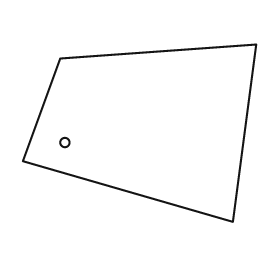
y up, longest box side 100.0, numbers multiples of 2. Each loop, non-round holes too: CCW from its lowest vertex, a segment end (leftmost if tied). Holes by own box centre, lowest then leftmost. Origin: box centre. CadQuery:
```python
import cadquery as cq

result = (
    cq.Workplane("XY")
    .moveTo(40.0, -38.0)
    .lineTo(50.0, 38.0)
    .lineTo(-34.0, 32.0)
    .lineTo(-50.0, -12.0)
    .close()
    .moveTo(-32.0, -4.0)
    .circle(2.0)
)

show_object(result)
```